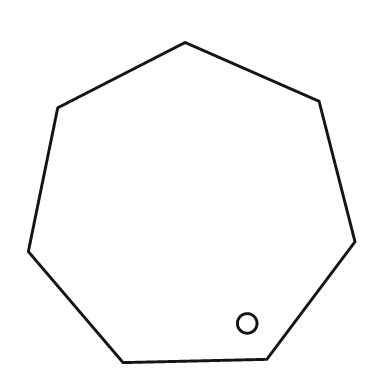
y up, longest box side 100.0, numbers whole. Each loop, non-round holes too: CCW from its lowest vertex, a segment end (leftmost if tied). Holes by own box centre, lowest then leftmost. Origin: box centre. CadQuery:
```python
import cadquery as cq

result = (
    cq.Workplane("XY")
    .moveTo(-21.0, -49.0)
    .lineTo(23.0, -48.0)
    .lineTo(50.0, -12.0)
    .lineTo(39.0, 31.0)
    .lineTo(-2.0, 49.0)
    .lineTo(-41.0, 29.0)
    .lineTo(-50.0, -15.0)
    .close()
    .moveTo(17.0, -37.0)
    .circle(3.0)
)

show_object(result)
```